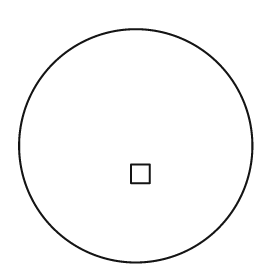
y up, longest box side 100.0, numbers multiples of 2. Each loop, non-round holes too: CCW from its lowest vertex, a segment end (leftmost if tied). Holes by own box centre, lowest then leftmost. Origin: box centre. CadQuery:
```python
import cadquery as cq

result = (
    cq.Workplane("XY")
    .moveTo(0.0, 0.0)
    .circle(50.0)
    .moveTo(-2.0, -16.0)
    .lineTo(6.0, -16.0)
    .lineTo(6.0, -8.0)
    .lineTo(-2.0, -8.0)
    .close()
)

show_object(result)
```